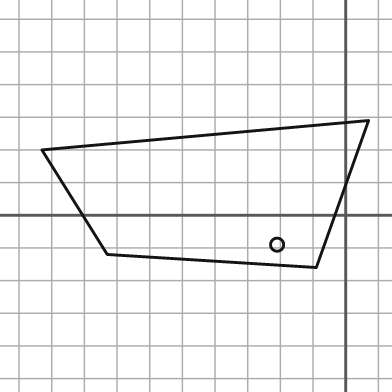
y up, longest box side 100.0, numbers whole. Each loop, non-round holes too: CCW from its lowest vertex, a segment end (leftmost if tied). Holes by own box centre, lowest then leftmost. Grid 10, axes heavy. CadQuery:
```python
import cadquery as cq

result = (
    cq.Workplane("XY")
    .moveTo(-9.0, -16.0)
    .lineTo(7.0, 29.0)
    .lineTo(-93.0, 20.0)
    .lineTo(-73.0, -12.0)
    .close()
    .moveTo(-21.0, -9.0)
    .circle(2.0)
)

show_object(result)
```